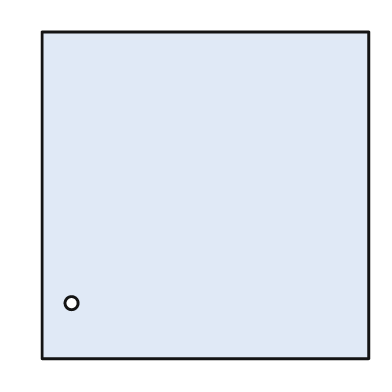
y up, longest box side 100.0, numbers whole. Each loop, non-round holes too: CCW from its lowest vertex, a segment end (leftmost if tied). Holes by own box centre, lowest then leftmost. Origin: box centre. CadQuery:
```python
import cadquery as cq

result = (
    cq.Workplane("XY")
    .moveTo(-50.0, -50.0)
    .lineTo(50.0, -50.0)
    .lineTo(50.0, 50.0)
    .lineTo(-50.0, 50.0)
    .close()
    .moveTo(-41.0, -33.0)
    .circle(2.0)
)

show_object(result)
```